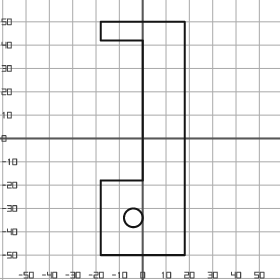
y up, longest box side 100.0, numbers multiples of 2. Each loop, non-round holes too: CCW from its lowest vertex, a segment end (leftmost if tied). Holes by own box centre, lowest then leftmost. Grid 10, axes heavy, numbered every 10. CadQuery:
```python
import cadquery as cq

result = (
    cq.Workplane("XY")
    .moveTo(-18.0, -50.0)
    .lineTo(18.0, -50.0)
    .lineTo(18.0, 50.0)
    .lineTo(-18.0, 50.0)
    .lineTo(-18.0, 42.0)
    .lineTo(0.0, 42.0)
    .lineTo(0.0, -18.0)
    .lineTo(-18.0, -18.0)
    .close()
    .moveTo(-4.0, -34.0)
    .circle(4.0)
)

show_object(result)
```